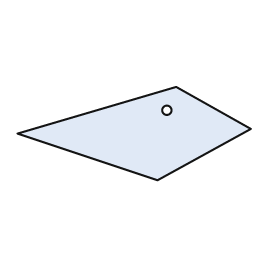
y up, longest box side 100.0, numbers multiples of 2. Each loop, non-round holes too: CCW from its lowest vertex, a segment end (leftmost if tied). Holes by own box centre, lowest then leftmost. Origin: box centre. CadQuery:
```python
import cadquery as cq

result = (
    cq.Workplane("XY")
    .moveTo(10.0, -20.0)
    .lineTo(50.0, 2.0)
    .lineTo(18.0, 20.0)
    .lineTo(-50.0, 0.0)
    .close()
    .moveTo(14.0, 10.0)
    .circle(2.0)
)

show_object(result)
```